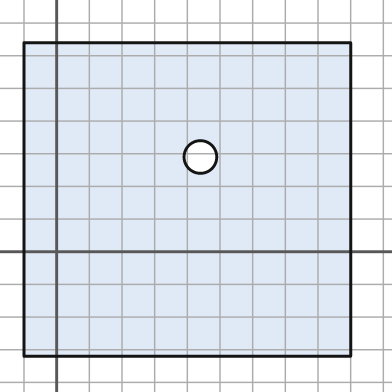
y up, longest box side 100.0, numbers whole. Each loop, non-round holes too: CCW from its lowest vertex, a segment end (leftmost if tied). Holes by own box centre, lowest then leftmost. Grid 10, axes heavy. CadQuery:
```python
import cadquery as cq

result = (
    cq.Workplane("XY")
    .moveTo(-10.0, -32.0)
    .lineTo(90.0, -32.0)
    .lineTo(90.0, 64.0)
    .lineTo(-10.0, 64.0)
    .close()
    .moveTo(44.0, 29.0)
    .circle(5.0)
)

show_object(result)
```